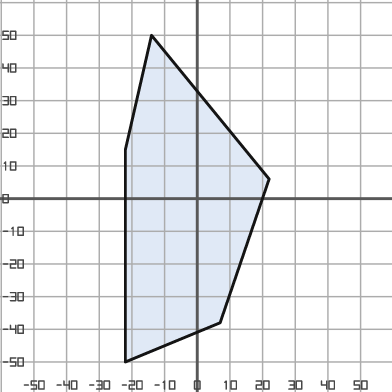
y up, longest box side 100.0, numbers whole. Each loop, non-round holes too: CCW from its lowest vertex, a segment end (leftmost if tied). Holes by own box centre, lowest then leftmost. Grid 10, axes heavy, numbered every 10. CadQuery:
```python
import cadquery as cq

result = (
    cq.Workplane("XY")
    .moveTo(-22.0, -50.0)
    .lineTo(7.0, -38.0)
    .lineTo(22.0, 6.0)
    .lineTo(-14.0, 50.0)
    .lineTo(-22.0, 15.0)
    .close()
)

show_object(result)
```